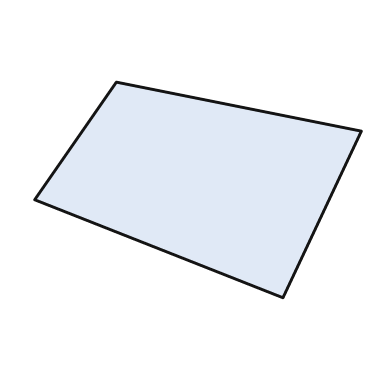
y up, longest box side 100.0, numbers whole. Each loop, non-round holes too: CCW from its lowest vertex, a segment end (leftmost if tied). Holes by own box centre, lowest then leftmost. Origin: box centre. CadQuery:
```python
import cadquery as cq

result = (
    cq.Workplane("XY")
    .moveTo(26.0, -33.0)
    .lineTo(50.0, 18.0)
    .lineTo(-25.0, 33.0)
    .lineTo(-50.0, -3.0)
    .close()
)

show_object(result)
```